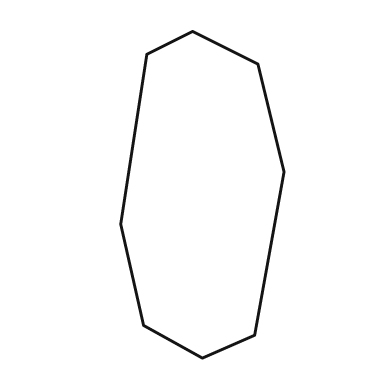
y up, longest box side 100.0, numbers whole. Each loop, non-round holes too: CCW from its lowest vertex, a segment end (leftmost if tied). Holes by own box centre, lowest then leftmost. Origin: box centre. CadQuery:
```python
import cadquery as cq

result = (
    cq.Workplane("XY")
    .moveTo(0.0, -50.0)
    .lineTo(16.0, -43.0)
    .lineTo(25.0, 7.0)
    .lineTo(17.0, 40.0)
    .lineTo(-3.0, 50.0)
    .lineTo(-17.0, 43.0)
    .lineTo(-25.0, -9.0)
    .lineTo(-18.0, -40.0)
    .close()
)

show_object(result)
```